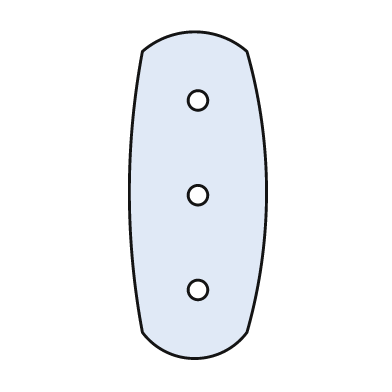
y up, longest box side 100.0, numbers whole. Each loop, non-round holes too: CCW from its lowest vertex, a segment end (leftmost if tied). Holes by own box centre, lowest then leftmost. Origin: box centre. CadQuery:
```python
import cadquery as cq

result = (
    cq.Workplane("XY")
    .moveTo(-17.0, -42.0)
    .threePointArc((-1.0, -50.0), (15.0, -42.0))
    .threePointArc((21.0, 1.0), (15.0, 44.0))
    .threePointArc((-1.0, 50.0), (-17.0, 44.0))
    .threePointArc((-21.0, 1.0), (-17.0, -42.0))
    .close()
    .moveTo(0.0, -29.0)
    .circle(3.0)
    .moveTo(0.0, 0.0)
    .circle(3.0)
    .moveTo(0.0, 29.0)
    .circle(3.0)
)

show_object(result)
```